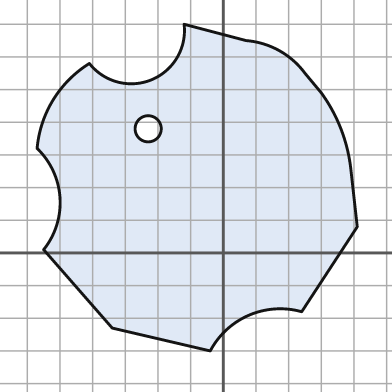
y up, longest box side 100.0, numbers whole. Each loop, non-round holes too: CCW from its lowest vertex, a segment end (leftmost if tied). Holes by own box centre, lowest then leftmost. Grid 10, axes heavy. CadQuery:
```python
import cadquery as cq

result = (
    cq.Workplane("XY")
    .moveTo(-4.0, -30.0)
    .threePointArc((8.0, -19.0), (24.0, -18.0))
    .lineTo(41.0, 8.0)
    .lineTo(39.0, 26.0)
    .threePointArc((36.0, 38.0), (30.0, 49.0))
    .lineTo(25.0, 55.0)
    .threePointArc((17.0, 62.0), (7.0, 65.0))
    .lineTo(-12.0, 70.0)
    .threePointArc((-22.0, 53.0), (-41.0, 58.0))
    .threePointArc((-52.0, 47.0), (-57.0, 32.0))
    .threePointArc((-50.0, 17.0), (-55.0, 1.0))
    .lineTo(-34.0, -23.0)
    .close()
    .moveTo(-23.0, 38.0)
    .circle(4.0)
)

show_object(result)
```